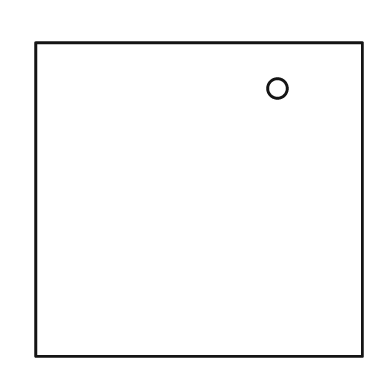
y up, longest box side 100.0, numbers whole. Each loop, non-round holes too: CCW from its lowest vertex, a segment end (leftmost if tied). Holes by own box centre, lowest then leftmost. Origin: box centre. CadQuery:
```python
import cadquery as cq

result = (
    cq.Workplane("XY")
    .moveTo(-50.0, -48.0)
    .lineTo(50.0, -48.0)
    .lineTo(50.0, 48.0)
    .lineTo(-50.0, 48.0)
    .close()
    .moveTo(24.0, 34.0)
    .circle(3.0)
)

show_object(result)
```